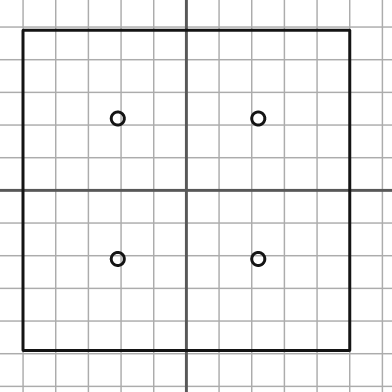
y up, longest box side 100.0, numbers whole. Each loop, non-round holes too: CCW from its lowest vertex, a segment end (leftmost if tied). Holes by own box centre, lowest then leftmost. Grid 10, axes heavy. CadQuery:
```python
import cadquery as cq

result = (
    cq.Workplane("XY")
    .moveTo(-50.0, -49.0)
    .lineTo(50.0, -49.0)
    .lineTo(50.0, 49.0)
    .lineTo(-50.0, 49.0)
    .close()
    .moveTo(-21.0, -21.0)
    .circle(2.0)
    .moveTo(22.0, -21.0)
    .circle(2.0)
    .moveTo(-21.0, 22.0)
    .circle(2.0)
    .moveTo(22.0, 22.0)
    .circle(2.0)
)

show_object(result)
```